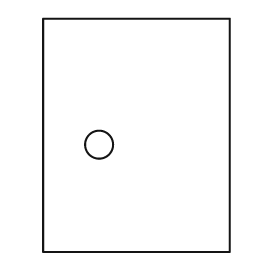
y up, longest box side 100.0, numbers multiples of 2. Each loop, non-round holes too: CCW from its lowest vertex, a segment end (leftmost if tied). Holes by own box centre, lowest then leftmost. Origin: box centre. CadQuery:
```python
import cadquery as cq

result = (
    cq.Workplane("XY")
    .moveTo(-40.0, -50.0)
    .lineTo(40.0, -50.0)
    .lineTo(40.0, 50.0)
    .lineTo(-40.0, 50.0)
    .close()
    .moveTo(-16.0, -4.0)
    .circle(6.0)
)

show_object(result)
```